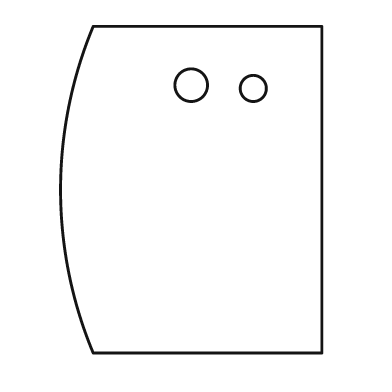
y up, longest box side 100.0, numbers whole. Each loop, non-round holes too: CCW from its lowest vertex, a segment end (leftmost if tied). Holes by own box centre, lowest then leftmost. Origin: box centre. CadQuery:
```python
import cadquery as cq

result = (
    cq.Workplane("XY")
    .moveTo(-30.0, -50.0)
    .lineTo(40.0, -50.0)
    .lineTo(40.0, 50.0)
    .lineTo(-30.0, 50.0)
    .threePointArc((-40.0, 0.0), (-30.0, -50.0))
    .close()
    .moveTo(19.0, 31.0)
    .circle(4.0)
    .moveTo(0.0, 32.0)
    .circle(5.0)
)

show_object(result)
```